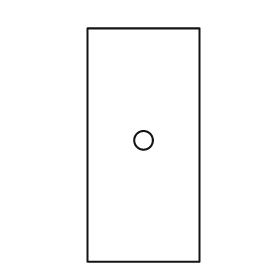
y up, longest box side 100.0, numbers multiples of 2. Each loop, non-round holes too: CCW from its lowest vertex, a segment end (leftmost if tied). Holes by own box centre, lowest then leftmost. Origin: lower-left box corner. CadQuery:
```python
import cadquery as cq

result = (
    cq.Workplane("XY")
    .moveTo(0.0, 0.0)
    .lineTo(48.0, 0.0)
    .lineTo(48.0, 100.0)
    .lineTo(0.0, 100.0)
    .close()
    .moveTo(24.0, 52.0)
    .circle(4.0)
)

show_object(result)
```